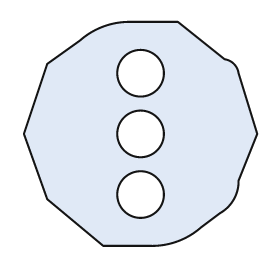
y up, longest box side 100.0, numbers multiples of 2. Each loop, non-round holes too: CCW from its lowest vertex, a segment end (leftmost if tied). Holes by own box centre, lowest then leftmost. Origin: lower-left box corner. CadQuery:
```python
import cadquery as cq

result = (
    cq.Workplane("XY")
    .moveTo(34.0, 0.0)
    .lineTo(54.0, 0.0)
    .threePointArc((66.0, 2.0), (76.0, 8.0))
    .lineTo(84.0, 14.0)
    .threePointArc((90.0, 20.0), (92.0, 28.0))
    .lineTo(100.0, 48.0)
    .lineTo(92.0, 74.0)
    .threePointArc((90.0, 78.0), (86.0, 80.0))
    .lineTo(66.0, 96.0)
    .lineTo(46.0, 96.0)
    .threePointArc((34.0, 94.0), (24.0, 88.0))
    .lineTo(10.0, 78.0)
    .lineTo(0.0, 48.0)
    .lineTo(10.0, 20.0)
    .close()
    .moveTo(50.0, 22.0)
    .circle(10.0)
    .moveTo(50.0, 48.0)
    .circle(10.0)
    .moveTo(50.0, 74.0)
    .circle(10.0)
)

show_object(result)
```